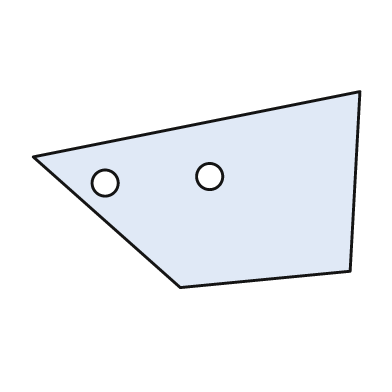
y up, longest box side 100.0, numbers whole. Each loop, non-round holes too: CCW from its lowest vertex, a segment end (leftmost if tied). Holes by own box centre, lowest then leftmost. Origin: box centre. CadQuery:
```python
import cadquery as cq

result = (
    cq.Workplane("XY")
    .moveTo(-5.0, -30.0)
    .lineTo(47.0, -25.0)
    .lineTo(50.0, 30.0)
    .lineTo(-50.0, 10.0)
    .close()
    .moveTo(-28.0, 2.0)
    .circle(4.0)
    .moveTo(4.0, 4.0)
    .circle(4.0)
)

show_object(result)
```